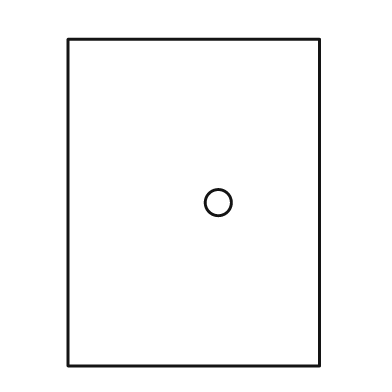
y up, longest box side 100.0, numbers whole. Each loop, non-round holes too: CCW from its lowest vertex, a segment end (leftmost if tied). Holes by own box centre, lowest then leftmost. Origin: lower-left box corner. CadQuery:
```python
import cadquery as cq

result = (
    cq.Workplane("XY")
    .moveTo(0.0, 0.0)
    .lineTo(77.0, 0.0)
    .lineTo(77.0, 100.0)
    .lineTo(0.0, 100.0)
    .close()
    .moveTo(46.0, 50.0)
    .circle(4.0)
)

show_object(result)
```